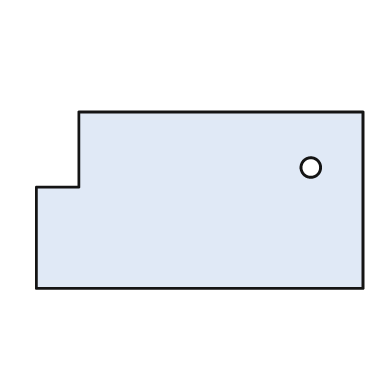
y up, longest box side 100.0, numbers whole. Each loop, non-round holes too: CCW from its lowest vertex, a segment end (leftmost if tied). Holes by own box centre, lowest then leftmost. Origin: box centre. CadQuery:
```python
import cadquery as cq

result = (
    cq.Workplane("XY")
    .moveTo(-50.0, -27.0)
    .lineTo(50.0, -27.0)
    .lineTo(50.0, 27.0)
    .lineTo(-37.0, 27.0)
    .lineTo(-37.0, 4.0)
    .lineTo(-50.0, 4.0)
    .close()
    .moveTo(34.0, 10.0)
    .circle(3.0)
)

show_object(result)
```